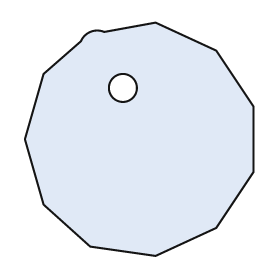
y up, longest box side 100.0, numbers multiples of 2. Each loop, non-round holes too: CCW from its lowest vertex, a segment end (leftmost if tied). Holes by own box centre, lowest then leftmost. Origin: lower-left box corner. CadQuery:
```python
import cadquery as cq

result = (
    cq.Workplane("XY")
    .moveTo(56.0, 0.0)
    .lineTo(82.0, 12.0)
    .lineTo(98.0, 36.0)
    .lineTo(98.0, 64.0)
    .lineTo(82.0, 88.0)
    .lineTo(56.0, 100.0)
    .lineTo(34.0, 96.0)
    .threePointArc((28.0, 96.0), (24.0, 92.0))
    .lineTo(8.0, 78.0)
    .lineTo(0.0, 50.0)
    .lineTo(8.0, 22.0)
    .lineTo(28.0, 4.0)
    .close()
    .moveTo(42.0, 72.0)
    .circle(6.0)
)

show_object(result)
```